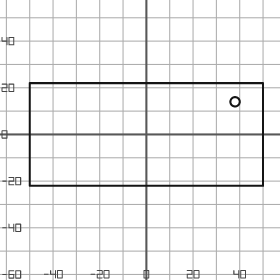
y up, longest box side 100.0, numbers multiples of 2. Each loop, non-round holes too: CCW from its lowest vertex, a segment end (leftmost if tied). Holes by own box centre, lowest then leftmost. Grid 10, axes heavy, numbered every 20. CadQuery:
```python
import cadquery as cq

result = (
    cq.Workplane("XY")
    .moveTo(-50.0, -22.0)
    .lineTo(50.0, -22.0)
    .lineTo(50.0, 22.0)
    .lineTo(-50.0, 22.0)
    .close()
    .moveTo(38.0, 14.0)
    .circle(2.0)
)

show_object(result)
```